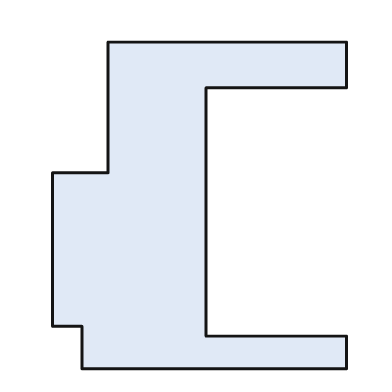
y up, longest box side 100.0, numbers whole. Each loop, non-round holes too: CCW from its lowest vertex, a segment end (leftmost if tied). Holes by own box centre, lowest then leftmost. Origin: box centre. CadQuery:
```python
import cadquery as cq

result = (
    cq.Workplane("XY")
    .moveTo(-36.0, -50.0)
    .lineTo(45.0, -50.0)
    .lineTo(45.0, -40.0)
    .lineTo(2.0, -40.0)
    .lineTo(2.0, 36.0)
    .lineTo(45.0, 36.0)
    .lineTo(45.0, 50.0)
    .lineTo(-28.0, 50.0)
    .lineTo(-28.0, 10.0)
    .lineTo(-45.0, 10.0)
    .lineTo(-45.0, -37.0)
    .lineTo(-36.0, -37.0)
    .close()
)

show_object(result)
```